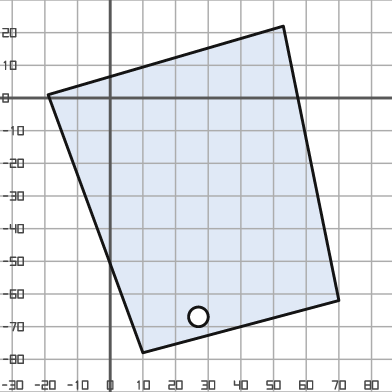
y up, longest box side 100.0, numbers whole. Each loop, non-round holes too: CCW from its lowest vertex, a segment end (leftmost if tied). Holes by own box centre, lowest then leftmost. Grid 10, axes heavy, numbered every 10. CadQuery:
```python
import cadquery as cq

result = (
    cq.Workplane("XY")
    .moveTo(10.0, -78.0)
    .lineTo(70.0, -62.0)
    .lineTo(53.0, 22.0)
    .lineTo(-19.0, 1.0)
    .close()
    .moveTo(27.0, -67.0)
    .circle(3.0)
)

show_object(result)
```